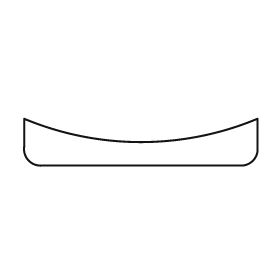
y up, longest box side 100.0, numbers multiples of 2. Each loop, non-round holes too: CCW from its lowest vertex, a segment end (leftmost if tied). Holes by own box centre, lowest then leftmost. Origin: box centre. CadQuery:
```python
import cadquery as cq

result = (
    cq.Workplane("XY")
    .moveTo(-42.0, -10.0)
    .lineTo(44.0, -10.0)
    .threePointArc((48.0, -8.0), (50.0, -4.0))
    .lineTo(50.0, 10.0)
    .threePointArc((0.0, 0.0), (-50.0, 10.0))
    .lineTo(-50.0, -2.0)
    .threePointArc((-48.0, -8.0), (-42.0, -10.0))
    .close()
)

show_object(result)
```